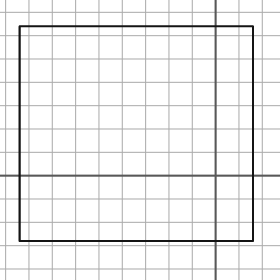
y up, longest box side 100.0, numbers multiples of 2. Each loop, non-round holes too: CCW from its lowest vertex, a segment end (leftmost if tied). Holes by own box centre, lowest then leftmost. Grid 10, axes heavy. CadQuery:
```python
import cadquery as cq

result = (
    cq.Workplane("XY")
    .moveTo(-84.0, -28.0)
    .lineTo(16.0, -28.0)
    .lineTo(16.0, 64.0)
    .lineTo(-84.0, 64.0)
    .close()
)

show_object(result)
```